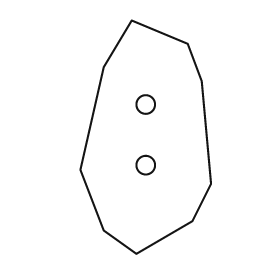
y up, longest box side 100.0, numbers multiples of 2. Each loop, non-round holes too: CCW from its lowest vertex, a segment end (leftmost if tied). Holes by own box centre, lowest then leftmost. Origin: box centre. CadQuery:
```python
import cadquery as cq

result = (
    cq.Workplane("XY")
    .moveTo(-4.0, -50.0)
    .lineTo(20.0, -36.0)
    .lineTo(28.0, -20.0)
    .lineTo(24.0, 24.0)
    .lineTo(18.0, 40.0)
    .lineTo(-6.0, 50.0)
    .lineTo(-18.0, 30.0)
    .lineTo(-28.0, -14.0)
    .lineTo(-18.0, -40.0)
    .close()
    .moveTo(0.0, -12.0)
    .circle(4.0)
    .moveTo(0.0, 14.0)
    .circle(4.0)
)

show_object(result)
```